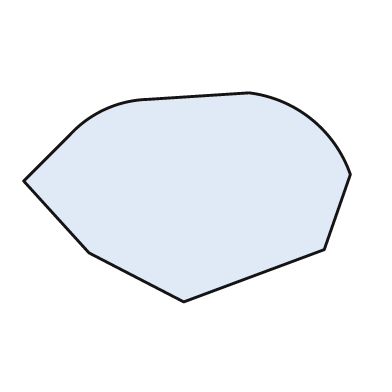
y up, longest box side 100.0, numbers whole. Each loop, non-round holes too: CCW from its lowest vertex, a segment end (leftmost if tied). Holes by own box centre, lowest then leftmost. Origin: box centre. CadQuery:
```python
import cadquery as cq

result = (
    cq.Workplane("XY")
    .moveTo(-1.0, -32.0)
    .lineTo(42.0, -16.0)
    .lineTo(50.0, 7.0)
    .threePointArc((38.0, 24.0), (19.0, 32.0))
    .lineTo(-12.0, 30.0)
    .threePointArc((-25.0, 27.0), (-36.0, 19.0))
    .lineTo(-50.0, 5.0)
    .lineTo(-30.0, -17.0)
    .close()
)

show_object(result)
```